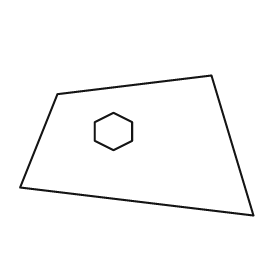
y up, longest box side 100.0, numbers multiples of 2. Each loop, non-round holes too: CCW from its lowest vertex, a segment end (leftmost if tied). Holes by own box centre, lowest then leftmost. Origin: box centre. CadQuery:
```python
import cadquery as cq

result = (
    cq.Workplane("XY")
    .moveTo(50.0, -30.0)
    .lineTo(32.0, 30.0)
    .lineTo(-34.0, 22.0)
    .lineTo(-50.0, -18.0)
    .close()
    .moveTo(-10.0, -2.0)
    .lineTo(-2.0, 2.0)
    .lineTo(-2.0, 10.0)
    .lineTo(-10.0, 14.0)
    .lineTo(-18.0, 10.0)
    .lineTo(-18.0, 2.0)
    .close()
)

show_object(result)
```